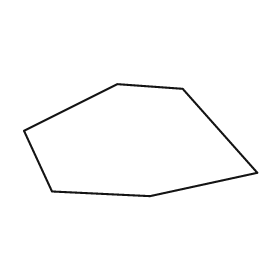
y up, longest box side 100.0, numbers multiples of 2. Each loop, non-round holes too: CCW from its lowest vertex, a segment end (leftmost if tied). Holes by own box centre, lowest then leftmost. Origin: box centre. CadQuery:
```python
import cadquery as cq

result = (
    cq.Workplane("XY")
    .moveTo(4.0, -24.0)
    .lineTo(50.0, -14.0)
    .lineTo(18.0, 22.0)
    .lineTo(-10.0, 24.0)
    .lineTo(-50.0, 4.0)
    .lineTo(-38.0, -22.0)
    .close()
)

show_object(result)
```